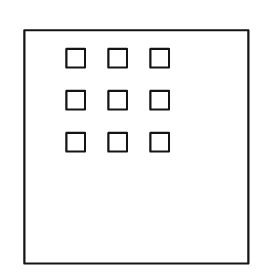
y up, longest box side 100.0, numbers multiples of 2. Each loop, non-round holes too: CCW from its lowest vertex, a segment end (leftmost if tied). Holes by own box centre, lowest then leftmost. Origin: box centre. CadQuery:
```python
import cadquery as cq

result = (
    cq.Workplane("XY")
    .moveTo(-48.0, -50.0)
    .lineTo(48.0, -50.0)
    .lineTo(48.0, 50.0)
    .lineTo(-48.0, 50.0)
    .close()
    .moveTo(-30.0, -2.0)
    .lineTo(-22.0, -2.0)
    .lineTo(-22.0, 6.0)
    .lineTo(-30.0, 6.0)
    .close()
    .moveTo(-12.0, -2.0)
    .lineTo(-4.0, -2.0)
    .lineTo(-4.0, 6.0)
    .lineTo(-12.0, 6.0)
    .close()
    .moveTo(6.0, -2.0)
    .lineTo(14.0, -2.0)
    .lineTo(14.0, 6.0)
    .lineTo(6.0, 6.0)
    .close()
    .moveTo(-30.0, 16.0)
    .lineTo(-22.0, 16.0)
    .lineTo(-22.0, 24.0)
    .lineTo(-30.0, 24.0)
    .close()
    .moveTo(-12.0, 16.0)
    .lineTo(-4.0, 16.0)
    .lineTo(-4.0, 24.0)
    .lineTo(-12.0, 24.0)
    .close()
    .moveTo(6.0, 16.0)
    .lineTo(14.0, 16.0)
    .lineTo(14.0, 24.0)
    .lineTo(6.0, 24.0)
    .close()
    .moveTo(-30.0, 34.0)
    .lineTo(-22.0, 34.0)
    .lineTo(-22.0, 42.0)
    .lineTo(-30.0, 42.0)
    .close()
    .moveTo(-12.0, 34.0)
    .lineTo(-4.0, 34.0)
    .lineTo(-4.0, 42.0)
    .lineTo(-12.0, 42.0)
    .close()
    .moveTo(6.0, 34.0)
    .lineTo(14.0, 34.0)
    .lineTo(14.0, 42.0)
    .lineTo(6.0, 42.0)
    .close()
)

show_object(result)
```